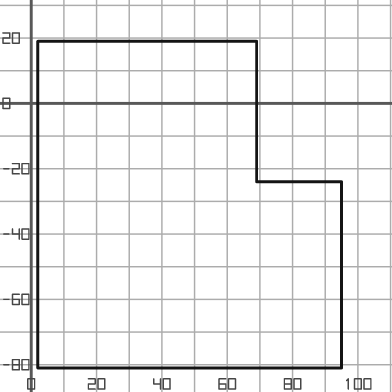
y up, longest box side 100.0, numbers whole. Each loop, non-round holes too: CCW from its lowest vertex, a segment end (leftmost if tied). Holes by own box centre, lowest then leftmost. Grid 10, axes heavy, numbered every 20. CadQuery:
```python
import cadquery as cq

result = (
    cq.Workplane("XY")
    .moveTo(2.0, -81.0)
    .lineTo(95.0, -81.0)
    .lineTo(95.0, -24.0)
    .lineTo(69.0, -24.0)
    .lineTo(69.0, 19.0)
    .lineTo(2.0, 19.0)
    .close()
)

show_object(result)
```